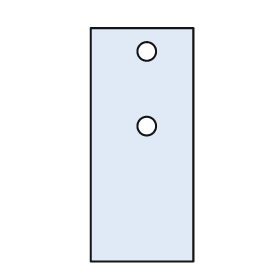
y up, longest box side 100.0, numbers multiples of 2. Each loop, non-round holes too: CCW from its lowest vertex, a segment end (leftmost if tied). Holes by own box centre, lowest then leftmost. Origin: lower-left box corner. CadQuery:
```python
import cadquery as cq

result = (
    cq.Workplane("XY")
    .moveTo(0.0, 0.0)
    .lineTo(44.0, 0.0)
    .lineTo(44.0, 100.0)
    .lineTo(0.0, 100.0)
    .close()
    .moveTo(24.0, 58.0)
    .circle(4.0)
    .moveTo(24.0, 90.0)
    .circle(4.0)
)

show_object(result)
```